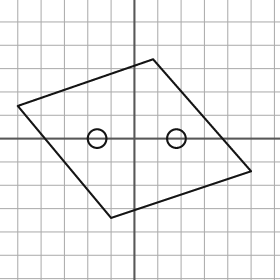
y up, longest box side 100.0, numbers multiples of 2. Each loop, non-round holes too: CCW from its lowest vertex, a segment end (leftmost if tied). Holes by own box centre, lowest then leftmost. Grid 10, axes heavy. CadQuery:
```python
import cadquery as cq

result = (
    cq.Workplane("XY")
    .moveTo(-10.0, -34.0)
    .lineTo(50.0, -14.0)
    .lineTo(8.0, 34.0)
    .lineTo(-50.0, 14.0)
    .close()
    .moveTo(-16.0, 0.0)
    .circle(4.0)
    .moveTo(18.0, 0.0)
    .circle(4.0)
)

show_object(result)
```